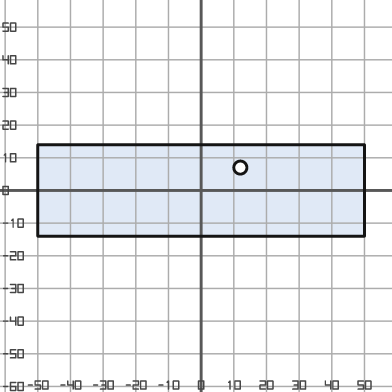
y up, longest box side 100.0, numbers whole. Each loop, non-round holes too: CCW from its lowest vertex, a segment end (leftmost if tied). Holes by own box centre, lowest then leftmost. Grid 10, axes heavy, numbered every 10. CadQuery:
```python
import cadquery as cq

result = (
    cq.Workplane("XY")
    .moveTo(-50.0, -14.0)
    .lineTo(50.0, -14.0)
    .lineTo(50.0, 14.0)
    .lineTo(-50.0, 14.0)
    .close()
    .moveTo(12.0, 7.0)
    .circle(2.0)
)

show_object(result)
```